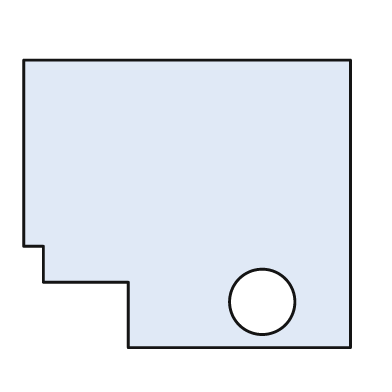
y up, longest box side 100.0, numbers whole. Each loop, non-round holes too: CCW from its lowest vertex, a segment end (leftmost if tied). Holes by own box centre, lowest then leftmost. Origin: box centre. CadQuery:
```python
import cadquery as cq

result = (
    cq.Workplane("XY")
    .moveTo(-18.0, -44.0)
    .lineTo(50.0, -44.0)
    .lineTo(50.0, 44.0)
    .lineTo(-50.0, 44.0)
    .lineTo(-50.0, -13.0)
    .lineTo(-44.0, -13.0)
    .lineTo(-44.0, -24.0)
    .lineTo(-18.0, -24.0)
    .close()
    .moveTo(23.0, -30.0)
    .circle(10.0)
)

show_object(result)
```